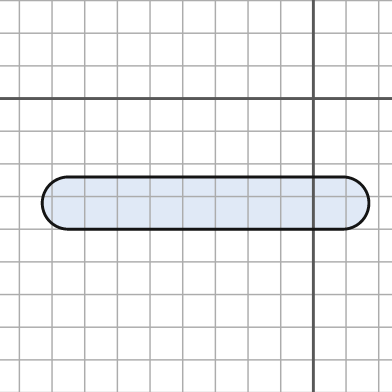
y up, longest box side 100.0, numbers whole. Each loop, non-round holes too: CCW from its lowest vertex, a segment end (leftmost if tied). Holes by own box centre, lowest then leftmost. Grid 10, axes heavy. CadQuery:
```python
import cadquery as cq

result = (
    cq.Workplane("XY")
    .moveTo(-75.0, -40.0)
    .lineTo(9.0, -40.0)
    .threePointArc((17.0, -32.0), (9.0, -24.0))
    .lineTo(-75.0, -24.0)
    .threePointArc((-83.0, -32.0), (-75.0, -40.0))
    .close()
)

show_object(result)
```